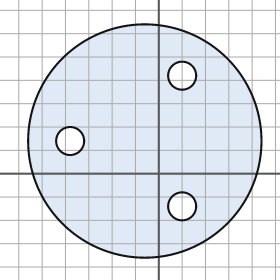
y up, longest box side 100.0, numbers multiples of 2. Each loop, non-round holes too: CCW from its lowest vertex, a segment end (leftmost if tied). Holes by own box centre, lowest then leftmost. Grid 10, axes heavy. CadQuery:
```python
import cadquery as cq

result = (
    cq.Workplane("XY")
    .moveTo(-6.0, 14.0)
    .circle(50.0)
    .moveTo(10.0, -14.0)
    .circle(6.0)
    .moveTo(-38.0, 14.0)
    .circle(6.0)
    .moveTo(10.0, 42.0)
    .circle(6.0)
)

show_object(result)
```